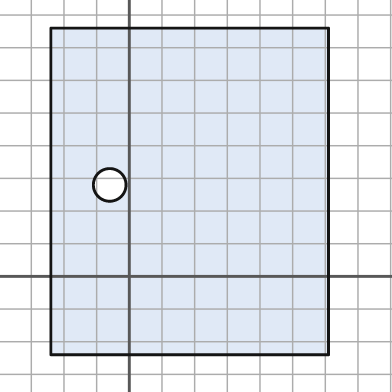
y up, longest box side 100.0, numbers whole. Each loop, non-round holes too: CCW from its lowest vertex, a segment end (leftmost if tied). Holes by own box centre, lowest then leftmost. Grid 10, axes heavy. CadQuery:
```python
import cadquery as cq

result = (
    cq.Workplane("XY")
    .moveTo(-24.0, -24.0)
    .lineTo(61.0, -24.0)
    .lineTo(61.0, 76.0)
    .lineTo(-24.0, 76.0)
    .close()
    .moveTo(-6.0, 28.0)
    .circle(5.0)
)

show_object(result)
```